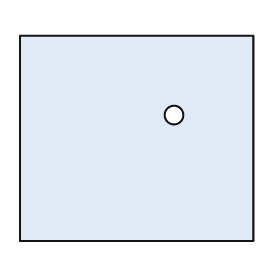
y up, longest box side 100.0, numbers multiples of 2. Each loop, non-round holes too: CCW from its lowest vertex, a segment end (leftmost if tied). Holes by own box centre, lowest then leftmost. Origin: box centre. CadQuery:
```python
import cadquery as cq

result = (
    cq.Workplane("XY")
    .moveTo(-50.0, -44.0)
    .lineTo(50.0, -44.0)
    .lineTo(50.0, 44.0)
    .lineTo(-50.0, 44.0)
    .close()
    .moveTo(16.0, 10.0)
    .circle(4.0)
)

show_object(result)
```